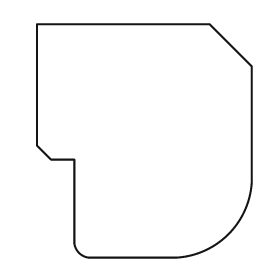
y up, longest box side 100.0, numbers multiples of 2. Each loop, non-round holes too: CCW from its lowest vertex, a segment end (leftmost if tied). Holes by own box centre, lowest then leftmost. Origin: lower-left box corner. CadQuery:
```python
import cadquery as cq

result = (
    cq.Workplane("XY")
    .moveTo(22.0, 0.0)
    .lineTo(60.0, 0.0)
    .threePointArc((82.0, 10.0), (92.0, 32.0))
    .lineTo(92.0, 82.0)
    .lineTo(74.0, 100.0)
    .lineTo(0.0, 100.0)
    .lineTo(0.0, 48.0)
    .lineTo(6.0, 42.0)
    .lineTo(16.0, 42.0)
    .lineTo(16.0, 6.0)
    .threePointArc((18.0, 2.0), (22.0, 0.0))
    .close()
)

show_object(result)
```